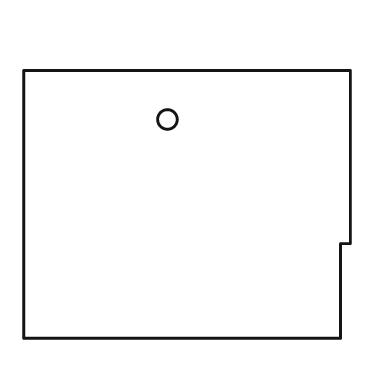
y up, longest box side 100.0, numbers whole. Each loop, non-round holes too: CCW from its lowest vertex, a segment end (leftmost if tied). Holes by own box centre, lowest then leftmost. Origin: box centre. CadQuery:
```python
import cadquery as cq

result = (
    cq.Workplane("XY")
    .moveTo(-50.0, -41.0)
    .lineTo(47.0, -41.0)
    .lineTo(47.0, -12.0)
    .lineTo(50.0, -12.0)
    .lineTo(50.0, 41.0)
    .lineTo(-50.0, 41.0)
    .close()
    .moveTo(-6.0, 26.0)
    .circle(3.0)
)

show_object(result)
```